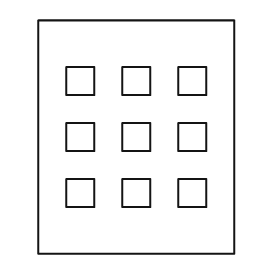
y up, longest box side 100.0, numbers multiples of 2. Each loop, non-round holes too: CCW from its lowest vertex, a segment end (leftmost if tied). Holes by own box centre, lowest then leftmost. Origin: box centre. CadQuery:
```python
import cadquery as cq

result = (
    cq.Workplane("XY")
    .moveTo(-42.0, -50.0)
    .lineTo(42.0, -50.0)
    .lineTo(42.0, 50.0)
    .lineTo(-42.0, 50.0)
    .close()
    .moveTo(-30.0, -30.0)
    .lineTo(-18.0, -30.0)
    .lineTo(-18.0, -18.0)
    .lineTo(-30.0, -18.0)
    .close()
    .moveTo(-6.0, -30.0)
    .lineTo(6.0, -30.0)
    .lineTo(6.0, -18.0)
    .lineTo(-6.0, -18.0)
    .close()
    .moveTo(18.0, -30.0)
    .lineTo(30.0, -30.0)
    .lineTo(30.0, -18.0)
    .lineTo(18.0, -18.0)
    .close()
    .moveTo(-30.0, -6.0)
    .lineTo(-18.0, -6.0)
    .lineTo(-18.0, 6.0)
    .lineTo(-30.0, 6.0)
    .close()
    .moveTo(-6.0, -6.0)
    .lineTo(6.0, -6.0)
    .lineTo(6.0, 6.0)
    .lineTo(-6.0, 6.0)
    .close()
    .moveTo(18.0, -6.0)
    .lineTo(30.0, -6.0)
    .lineTo(30.0, 6.0)
    .lineTo(18.0, 6.0)
    .close()
    .moveTo(-30.0, 18.0)
    .lineTo(-18.0, 18.0)
    .lineTo(-18.0, 30.0)
    .lineTo(-30.0, 30.0)
    .close()
    .moveTo(-6.0, 18.0)
    .lineTo(6.0, 18.0)
    .lineTo(6.0, 30.0)
    .lineTo(-6.0, 30.0)
    .close()
    .moveTo(18.0, 18.0)
    .lineTo(30.0, 18.0)
    .lineTo(30.0, 30.0)
    .lineTo(18.0, 30.0)
    .close()
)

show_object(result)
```